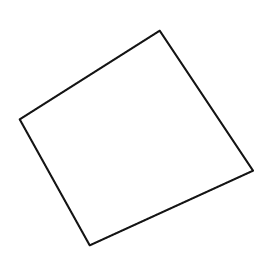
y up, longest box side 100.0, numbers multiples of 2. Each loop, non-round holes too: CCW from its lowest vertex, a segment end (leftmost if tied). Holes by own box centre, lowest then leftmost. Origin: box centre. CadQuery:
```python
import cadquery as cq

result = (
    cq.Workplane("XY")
    .moveTo(-20.0, -46.0)
    .lineTo(50.0, -14.0)
    .lineTo(10.0, 46.0)
    .lineTo(-50.0, 8.0)
    .close()
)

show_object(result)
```